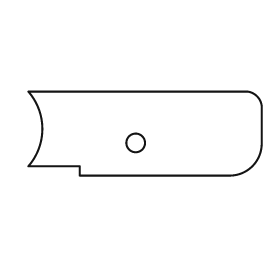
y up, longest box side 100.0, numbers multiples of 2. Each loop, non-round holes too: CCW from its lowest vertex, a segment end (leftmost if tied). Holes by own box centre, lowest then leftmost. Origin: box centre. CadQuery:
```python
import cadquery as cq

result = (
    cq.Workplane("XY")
    .moveTo(-28.0, -18.0)
    .lineTo(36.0, -18.0)
    .threePointArc((46.0, -14.0), (50.0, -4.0))
    .lineTo(50.0, 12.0)
    .threePointArc((48.0, 16.0), (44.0, 18.0))
    .lineTo(-50.0, 18.0)
    .threePointArc((-44.0, 2.0), (-50.0, -14.0))
    .lineTo(-28.0, -14.0)
    .close()
    .moveTo(-4.0, -4.0)
    .circle(4.0)
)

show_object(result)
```